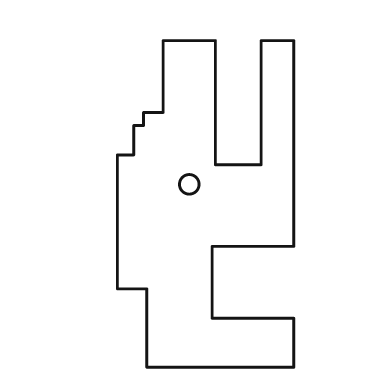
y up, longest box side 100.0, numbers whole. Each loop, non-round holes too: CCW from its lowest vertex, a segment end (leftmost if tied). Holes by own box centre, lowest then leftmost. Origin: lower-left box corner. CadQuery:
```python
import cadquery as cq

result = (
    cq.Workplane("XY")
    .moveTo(9.0, 0.0)
    .lineTo(54.0, 0.0)
    .lineTo(54.0, 15.0)
    .lineTo(29.0, 15.0)
    .lineTo(29.0, 37.0)
    .lineTo(54.0, 37.0)
    .lineTo(54.0, 100.0)
    .lineTo(44.0, 100.0)
    .lineTo(44.0, 62.0)
    .lineTo(30.0, 62.0)
    .lineTo(30.0, 100.0)
    .lineTo(14.0, 100.0)
    .lineTo(14.0, 78.0)
    .lineTo(8.0, 78.0)
    .lineTo(8.0, 74.0)
    .lineTo(5.0, 74.0)
    .lineTo(5.0, 65.0)
    .lineTo(0.0, 65.0)
    .lineTo(0.0, 24.0)
    .lineTo(9.0, 24.0)
    .close()
    .moveTo(22.0, 56.0)
    .circle(3.0)
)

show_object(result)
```